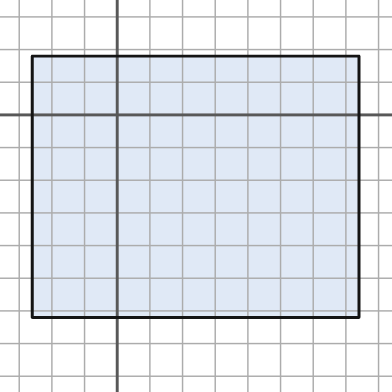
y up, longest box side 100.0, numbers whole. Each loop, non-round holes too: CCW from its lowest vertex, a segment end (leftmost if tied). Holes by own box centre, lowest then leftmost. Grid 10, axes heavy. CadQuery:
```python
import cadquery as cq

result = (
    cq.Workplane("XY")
    .moveTo(-26.0, -62.0)
    .lineTo(74.0, -62.0)
    .lineTo(74.0, 18.0)
    .lineTo(-26.0, 18.0)
    .close()
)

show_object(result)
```